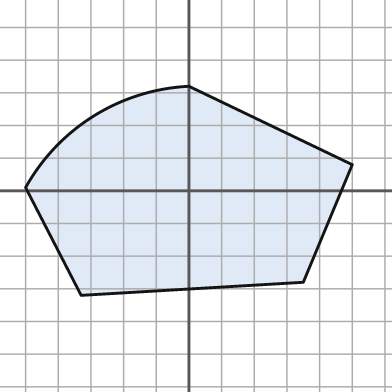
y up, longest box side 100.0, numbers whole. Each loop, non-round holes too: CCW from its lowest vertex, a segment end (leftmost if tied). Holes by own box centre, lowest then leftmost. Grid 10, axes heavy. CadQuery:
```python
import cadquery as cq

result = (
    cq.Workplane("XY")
    .moveTo(-33.0, -32.0)
    .lineTo(35.0, -28.0)
    .lineTo(50.0, 8.0)
    .lineTo(0.0, 32.0)
    .threePointArc((-29.0, 23.0), (-50.0, 1.0))
    .close()
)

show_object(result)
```